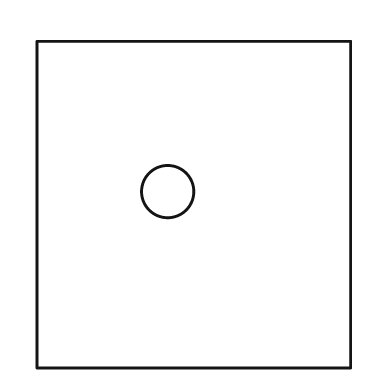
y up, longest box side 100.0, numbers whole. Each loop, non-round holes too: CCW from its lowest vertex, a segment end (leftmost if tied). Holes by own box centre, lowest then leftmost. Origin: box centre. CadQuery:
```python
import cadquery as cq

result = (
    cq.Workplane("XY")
    .moveTo(-48.0, -50.0)
    .lineTo(48.0, -50.0)
    .lineTo(48.0, 50.0)
    .lineTo(-48.0, 50.0)
    .close()
    .moveTo(-8.0, 4.0)
    .circle(8.0)
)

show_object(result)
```